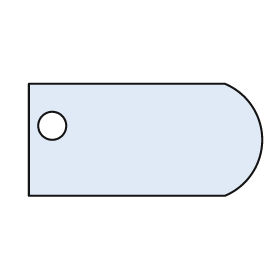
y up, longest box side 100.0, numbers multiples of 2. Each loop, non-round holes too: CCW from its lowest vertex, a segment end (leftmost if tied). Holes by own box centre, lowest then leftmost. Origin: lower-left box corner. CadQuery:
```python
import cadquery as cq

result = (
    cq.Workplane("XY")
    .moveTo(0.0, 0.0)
    .lineTo(84.0, 0.0)
    .threePointArc((100.0, 24.0), (84.0, 48.0))
    .lineTo(0.0, 48.0)
    .close()
    .moveTo(10.0, 30.0)
    .circle(6.0)
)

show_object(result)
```